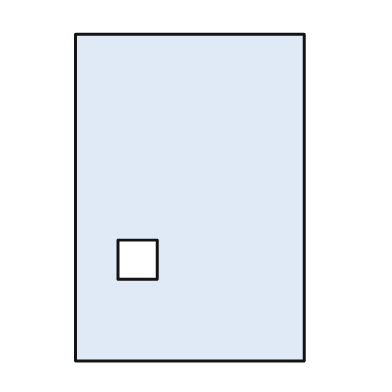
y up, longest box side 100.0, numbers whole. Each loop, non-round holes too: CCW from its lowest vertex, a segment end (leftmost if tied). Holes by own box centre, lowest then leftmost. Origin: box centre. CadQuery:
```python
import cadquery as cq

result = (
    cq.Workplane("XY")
    .moveTo(-35.0, -50.0)
    .lineTo(35.0, -50.0)
    .lineTo(35.0, 50.0)
    .lineTo(-35.0, 50.0)
    .close()
    .moveTo(-22.0, -25.0)
    .lineTo(-10.0, -25.0)
    .lineTo(-10.0, -13.0)
    .lineTo(-22.0, -13.0)
    .close()
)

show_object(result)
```